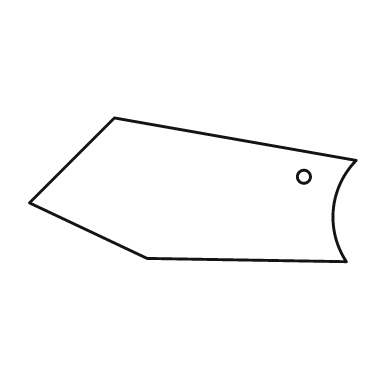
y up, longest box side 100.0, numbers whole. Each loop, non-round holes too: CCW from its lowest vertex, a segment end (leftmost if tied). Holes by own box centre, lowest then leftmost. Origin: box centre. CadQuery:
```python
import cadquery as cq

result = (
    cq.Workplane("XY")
    .moveTo(47.0, -22.0)
    .threePointArc((43.0, -6.0), (50.0, 9.0))
    .lineTo(-24.0, 22.0)
    .lineTo(-50.0, -4.0)
    .lineTo(-14.0, -21.0)
    .close()
    .moveTo(34.0, 4.0)
    .circle(2.0)
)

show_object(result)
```